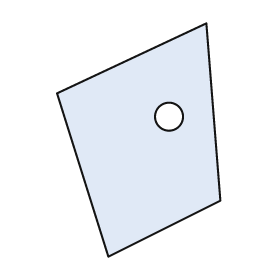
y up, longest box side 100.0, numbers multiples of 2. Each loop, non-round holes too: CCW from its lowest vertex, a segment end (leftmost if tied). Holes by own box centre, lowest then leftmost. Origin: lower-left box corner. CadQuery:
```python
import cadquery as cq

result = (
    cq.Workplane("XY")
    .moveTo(22.0, 0.0)
    .lineTo(70.0, 24.0)
    .lineTo(64.0, 100.0)
    .lineTo(0.0, 70.0)
    .close()
    .moveTo(48.0, 60.0)
    .circle(6.0)
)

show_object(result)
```